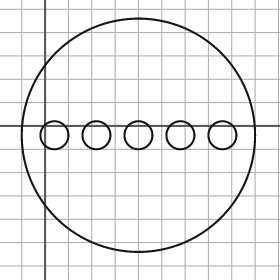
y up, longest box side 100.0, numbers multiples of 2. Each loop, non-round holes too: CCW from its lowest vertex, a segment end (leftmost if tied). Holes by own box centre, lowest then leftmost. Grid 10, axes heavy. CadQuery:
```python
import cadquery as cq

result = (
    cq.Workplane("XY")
    .moveTo(40.0, -4.0)
    .circle(50.0)
    .moveTo(4.0, -4.0)
    .circle(6.0)
    .moveTo(22.0, -4.0)
    .circle(6.0)
    .moveTo(40.0, -4.0)
    .circle(6.0)
    .moveTo(58.0, -4.0)
    .circle(6.0)
    .moveTo(76.0, -4.0)
    .circle(6.0)
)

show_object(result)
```